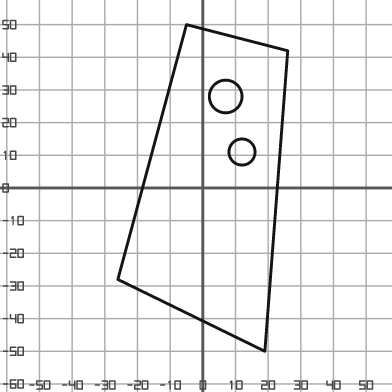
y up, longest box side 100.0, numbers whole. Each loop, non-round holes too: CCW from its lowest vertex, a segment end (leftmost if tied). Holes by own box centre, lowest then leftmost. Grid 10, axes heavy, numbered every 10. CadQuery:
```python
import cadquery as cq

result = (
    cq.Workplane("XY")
    .moveTo(19.0, -50.0)
    .lineTo(26.0, 42.0)
    .lineTo(-5.0, 50.0)
    .lineTo(-26.0, -28.0)
    .close()
    .moveTo(12.0, 11.0)
    .circle(4.0)
    .moveTo(7.0, 28.0)
    .circle(5.0)
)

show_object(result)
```